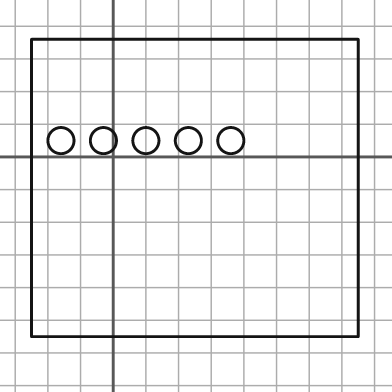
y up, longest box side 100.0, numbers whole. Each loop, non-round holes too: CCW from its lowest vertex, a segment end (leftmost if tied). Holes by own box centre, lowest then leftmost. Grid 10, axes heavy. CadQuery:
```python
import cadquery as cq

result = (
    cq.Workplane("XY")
    .moveTo(-25.0, -55.0)
    .lineTo(75.0, -55.0)
    .lineTo(75.0, 36.0)
    .lineTo(-25.0, 36.0)
    .close()
    .moveTo(-16.0, 5.0)
    .circle(4.0)
    .moveTo(-3.0, 5.0)
    .circle(4.0)
    .moveTo(10.0, 5.0)
    .circle(4.0)
    .moveTo(23.0, 5.0)
    .circle(4.0)
    .moveTo(36.0, 5.0)
    .circle(4.0)
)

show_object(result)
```